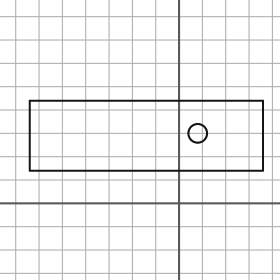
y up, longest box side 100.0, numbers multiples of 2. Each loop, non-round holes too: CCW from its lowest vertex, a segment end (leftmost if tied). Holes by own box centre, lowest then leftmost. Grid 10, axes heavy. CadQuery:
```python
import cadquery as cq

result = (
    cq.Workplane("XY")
    .moveTo(-64.0, 14.0)
    .lineTo(36.0, 14.0)
    .lineTo(36.0, 44.0)
    .lineTo(-64.0, 44.0)
    .close()
    .moveTo(8.0, 30.0)
    .circle(4.0)
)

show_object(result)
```